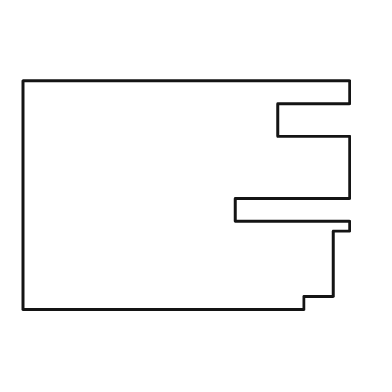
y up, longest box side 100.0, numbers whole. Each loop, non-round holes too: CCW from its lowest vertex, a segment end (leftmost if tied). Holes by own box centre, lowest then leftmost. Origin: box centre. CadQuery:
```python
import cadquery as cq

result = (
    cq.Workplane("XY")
    .moveTo(-50.0, -35.0)
    .lineTo(36.0, -35.0)
    .lineTo(36.0, -31.0)
    .lineTo(45.0, -31.0)
    .lineTo(45.0, -11.0)
    .lineTo(50.0, -11.0)
    .lineTo(50.0, -8.0)
    .lineTo(15.0, -8.0)
    .lineTo(15.0, -1.0)
    .lineTo(50.0, -1.0)
    .lineTo(50.0, 18.0)
    .lineTo(28.0, 18.0)
    .lineTo(28.0, 28.0)
    .lineTo(50.0, 28.0)
    .lineTo(50.0, 35.0)
    .lineTo(-50.0, 35.0)
    .close()
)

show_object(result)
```